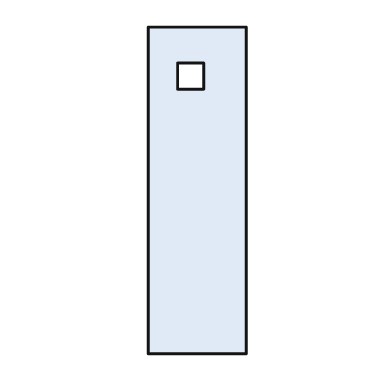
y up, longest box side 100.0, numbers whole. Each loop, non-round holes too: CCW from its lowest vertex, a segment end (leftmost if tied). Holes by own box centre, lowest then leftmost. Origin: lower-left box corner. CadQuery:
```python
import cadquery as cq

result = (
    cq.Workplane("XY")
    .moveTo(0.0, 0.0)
    .lineTo(30.0, 0.0)
    .lineTo(30.0, 100.0)
    .lineTo(0.0, 100.0)
    .close()
    .moveTo(9.0, 81.0)
    .lineTo(17.0, 81.0)
    .lineTo(17.0, 89.0)
    .lineTo(9.0, 89.0)
    .close()
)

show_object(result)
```